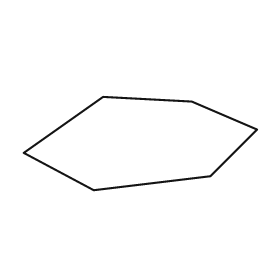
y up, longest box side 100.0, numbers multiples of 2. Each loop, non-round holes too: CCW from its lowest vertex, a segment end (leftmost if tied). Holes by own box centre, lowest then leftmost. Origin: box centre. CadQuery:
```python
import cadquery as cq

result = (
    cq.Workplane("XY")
    .moveTo(-20.0, -20.0)
    .lineTo(30.0, -14.0)
    .lineTo(50.0, 6.0)
    .lineTo(22.0, 18.0)
    .lineTo(-16.0, 20.0)
    .lineTo(-50.0, -4.0)
    .close()
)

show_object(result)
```